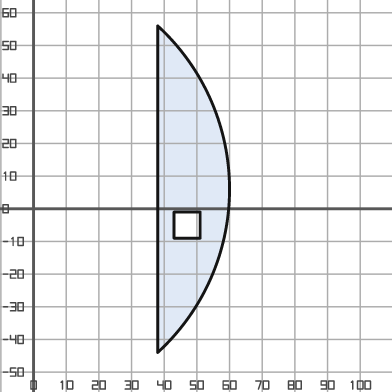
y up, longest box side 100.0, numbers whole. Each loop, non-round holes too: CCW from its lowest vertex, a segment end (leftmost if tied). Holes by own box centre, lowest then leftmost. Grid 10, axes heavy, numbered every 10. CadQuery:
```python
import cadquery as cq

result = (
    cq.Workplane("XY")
    .moveTo(38.0, -44.0)
    .threePointArc((60.0, 6.0), (38.0, 56.0))
    .close()
    .moveTo(43.0, -9.0)
    .lineTo(51.0, -9.0)
    .lineTo(51.0, -1.0)
    .lineTo(43.0, -1.0)
    .close()
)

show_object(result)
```